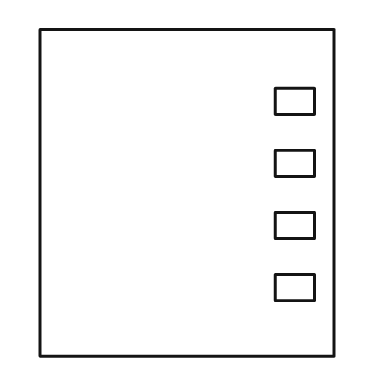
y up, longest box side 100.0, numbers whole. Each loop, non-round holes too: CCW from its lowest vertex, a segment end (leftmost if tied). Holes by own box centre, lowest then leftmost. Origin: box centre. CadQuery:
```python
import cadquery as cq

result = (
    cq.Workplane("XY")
    .moveTo(-45.0, -50.0)
    .lineTo(45.0, -50.0)
    .lineTo(45.0, 50.0)
    .lineTo(-45.0, 50.0)
    .close()
    .moveTo(27.0, -33.0)
    .lineTo(39.0, -33.0)
    .lineTo(39.0, -25.0)
    .lineTo(27.0, -25.0)
    .close()
    .moveTo(27.0, -14.0)
    .lineTo(39.0, -14.0)
    .lineTo(39.0, -6.0)
    .lineTo(27.0, -6.0)
    .close()
    .moveTo(27.0, 5.0)
    .lineTo(39.0, 5.0)
    .lineTo(39.0, 13.0)
    .lineTo(27.0, 13.0)
    .close()
    .moveTo(27.0, 24.0)
    .lineTo(39.0, 24.0)
    .lineTo(39.0, 32.0)
    .lineTo(27.0, 32.0)
    .close()
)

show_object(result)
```